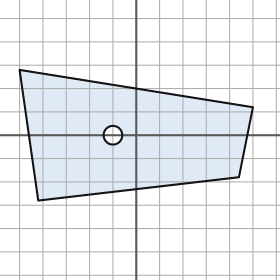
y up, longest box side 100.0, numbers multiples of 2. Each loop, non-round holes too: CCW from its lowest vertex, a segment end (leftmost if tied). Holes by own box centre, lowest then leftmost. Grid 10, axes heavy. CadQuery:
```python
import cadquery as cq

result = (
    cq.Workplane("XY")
    .moveTo(-42.0, -28.0)
    .lineTo(44.0, -18.0)
    .lineTo(50.0, 12.0)
    .lineTo(-50.0, 28.0)
    .close()
    .moveTo(-10.0, 0.0)
    .circle(4.0)
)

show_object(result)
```